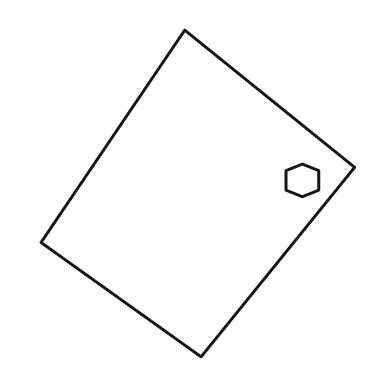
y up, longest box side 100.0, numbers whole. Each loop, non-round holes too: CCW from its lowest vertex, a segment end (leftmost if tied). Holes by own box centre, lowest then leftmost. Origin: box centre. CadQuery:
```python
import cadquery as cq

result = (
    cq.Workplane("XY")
    .moveTo(1.0, -50.0)
    .lineTo(48.0, 8.0)
    .lineTo(-4.0, 50.0)
    .lineTo(-48.0, -15.0)
    .close()
    .moveTo(32.0, -1.0)
    .lineTo(37.0, 1.0)
    .lineTo(37.0, 7.0)
    .lineTo(32.0, 9.0)
    .lineTo(27.0, 7.0)
    .lineTo(27.0, 1.0)
    .close()
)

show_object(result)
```